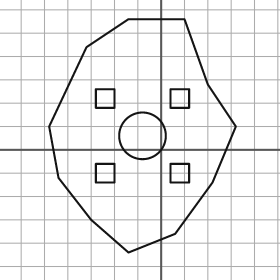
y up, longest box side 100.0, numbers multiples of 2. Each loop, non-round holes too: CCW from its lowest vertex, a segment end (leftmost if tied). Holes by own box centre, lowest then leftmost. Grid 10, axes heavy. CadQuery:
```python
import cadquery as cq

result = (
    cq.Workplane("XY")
    .moveTo(-14.0, -44.0)
    .lineTo(6.0, -36.0)
    .lineTo(22.0, -14.0)
    .lineTo(32.0, 10.0)
    .lineTo(20.0, 28.0)
    .lineTo(10.0, 56.0)
    .lineTo(-14.0, 56.0)
    .lineTo(-32.0, 44.0)
    .lineTo(-48.0, 10.0)
    .lineTo(-44.0, -12.0)
    .lineTo(-30.0, -30.0)
    .close()
    .moveTo(-28.0, -14.0)
    .lineTo(-20.0, -14.0)
    .lineTo(-20.0, -6.0)
    .lineTo(-28.0, -6.0)
    .close()
    .moveTo(4.0, -14.0)
    .lineTo(12.0, -14.0)
    .lineTo(12.0, -6.0)
    .lineTo(4.0, -6.0)
    .close()
    .moveTo(-8.0, 6.0)
    .circle(10.0)
    .moveTo(-28.0, 18.0)
    .lineTo(-20.0, 18.0)
    .lineTo(-20.0, 26.0)
    .lineTo(-28.0, 26.0)
    .close()
    .moveTo(4.0, 18.0)
    .lineTo(12.0, 18.0)
    .lineTo(12.0, 26.0)
    .lineTo(4.0, 26.0)
    .close()
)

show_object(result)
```